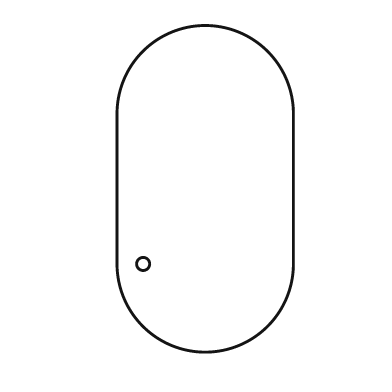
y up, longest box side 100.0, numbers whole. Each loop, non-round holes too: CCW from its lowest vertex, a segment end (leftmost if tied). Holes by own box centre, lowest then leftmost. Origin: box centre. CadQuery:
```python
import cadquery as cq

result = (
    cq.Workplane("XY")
    .moveTo(-27.0, -23.0)
    .threePointArc((0.0, -50.0), (27.0, -23.0))
    .lineTo(27.0, 23.0)
    .threePointArc((0.0, 50.0), (-27.0, 23.0))
    .close()
    .moveTo(-19.0, -23.0)
    .circle(2.0)
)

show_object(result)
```